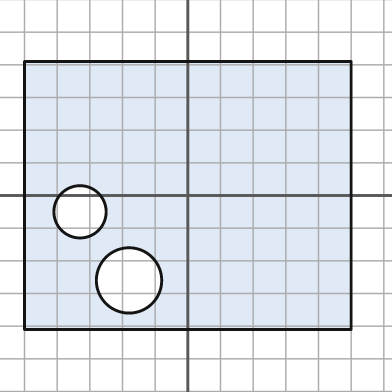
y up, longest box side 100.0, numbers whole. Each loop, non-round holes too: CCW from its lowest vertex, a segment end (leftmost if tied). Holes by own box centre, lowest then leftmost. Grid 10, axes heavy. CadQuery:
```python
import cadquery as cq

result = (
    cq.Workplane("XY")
    .moveTo(-50.0, -41.0)
    .lineTo(50.0, -41.0)
    .lineTo(50.0, 41.0)
    .lineTo(-50.0, 41.0)
    .close()
    .moveTo(-18.0, -26.0)
    .circle(10.0)
    .moveTo(-33.0, -5.0)
    .circle(8.0)
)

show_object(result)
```